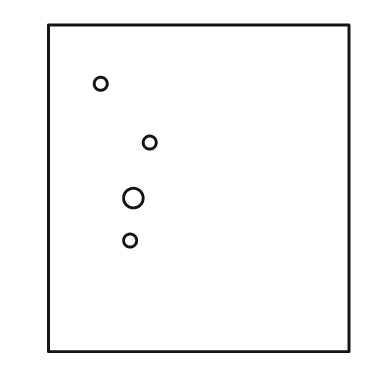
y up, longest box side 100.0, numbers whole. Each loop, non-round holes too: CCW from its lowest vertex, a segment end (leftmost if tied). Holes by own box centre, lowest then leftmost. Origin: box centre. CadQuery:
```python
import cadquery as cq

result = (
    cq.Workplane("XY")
    .moveTo(-46.0, -50.0)
    .lineTo(46.0, -50.0)
    .lineTo(46.0, 50.0)
    .lineTo(-46.0, 50.0)
    .close()
    .moveTo(-21.0, -16.0)
    .circle(2.0)
    .moveTo(-20.0, -3.0)
    .circle(3.0)
    .moveTo(-15.0, 14.0)
    .circle(2.0)
    .moveTo(-30.0, 32.0)
    .circle(2.0)
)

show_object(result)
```